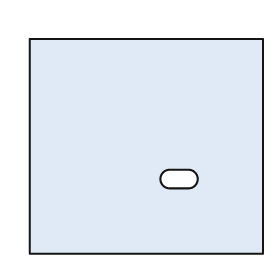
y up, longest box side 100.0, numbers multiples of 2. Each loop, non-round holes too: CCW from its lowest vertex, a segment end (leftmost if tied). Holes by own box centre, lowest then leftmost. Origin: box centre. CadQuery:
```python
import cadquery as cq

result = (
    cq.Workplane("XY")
    .moveTo(-50.0, -46.0)
    .lineTo(50.0, -46.0)
    .lineTo(50.0, 46.0)
    .lineTo(-50.0, 46.0)
    .close()
    .moveTo(10.0, -18.0)
    .lineTo(18.0, -18.0)
    .threePointArc((22.0, -14.0), (18.0, -10.0))
    .lineTo(10.0, -10.0)
    .threePointArc((6.0, -14.0), (10.0, -18.0))
    .close()
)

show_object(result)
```